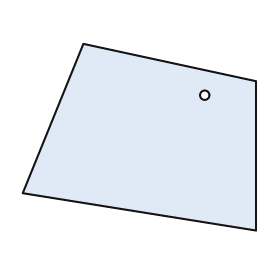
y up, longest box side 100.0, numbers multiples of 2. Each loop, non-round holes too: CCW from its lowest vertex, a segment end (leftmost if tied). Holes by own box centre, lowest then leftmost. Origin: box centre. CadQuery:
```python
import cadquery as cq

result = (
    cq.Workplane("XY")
    .moveTo(50.0, -40.0)
    .lineTo(50.0, 24.0)
    .lineTo(-24.0, 40.0)
    .lineTo(-50.0, -24.0)
    .close()
    .moveTo(28.0, 18.0)
    .circle(2.0)
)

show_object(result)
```